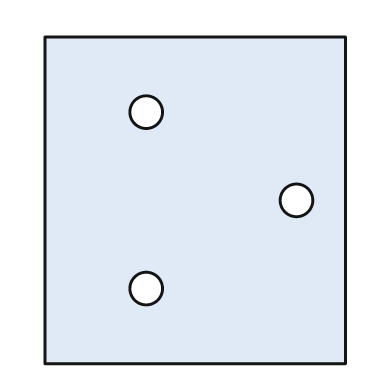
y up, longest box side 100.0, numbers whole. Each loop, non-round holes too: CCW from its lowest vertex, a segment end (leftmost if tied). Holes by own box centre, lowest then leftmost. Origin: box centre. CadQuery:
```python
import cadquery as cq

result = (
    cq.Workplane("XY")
    .moveTo(-46.0, -50.0)
    .lineTo(46.0, -50.0)
    .lineTo(46.0, 50.0)
    .lineTo(-46.0, 50.0)
    .close()
    .moveTo(-15.0, -27.0)
    .circle(5.0)
    .moveTo(31.0, 0.0)
    .circle(5.0)
    .moveTo(-15.0, 27.0)
    .circle(5.0)
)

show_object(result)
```